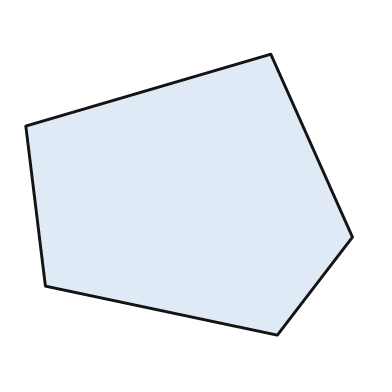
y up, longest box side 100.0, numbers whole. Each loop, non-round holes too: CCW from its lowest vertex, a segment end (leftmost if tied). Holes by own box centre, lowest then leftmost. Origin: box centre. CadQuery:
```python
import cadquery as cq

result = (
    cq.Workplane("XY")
    .moveTo(27.0, -43.0)
    .lineTo(50.0, -13.0)
    .lineTo(25.0, 43.0)
    .lineTo(-50.0, 21.0)
    .lineTo(-44.0, -28.0)
    .close()
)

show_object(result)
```